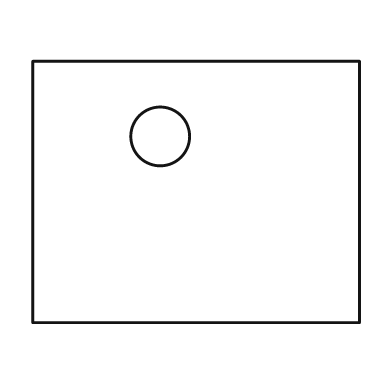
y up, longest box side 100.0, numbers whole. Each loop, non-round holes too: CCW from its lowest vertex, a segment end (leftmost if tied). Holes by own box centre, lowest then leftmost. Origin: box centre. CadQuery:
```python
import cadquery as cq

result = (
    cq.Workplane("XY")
    .moveTo(-50.0, -40.0)
    .lineTo(50.0, -40.0)
    .lineTo(50.0, 40.0)
    .lineTo(-50.0, 40.0)
    .close()
    .moveTo(-11.0, 17.0)
    .circle(9.0)
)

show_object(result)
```